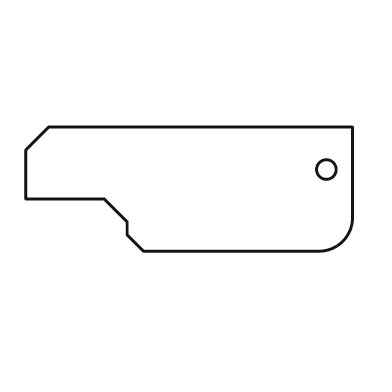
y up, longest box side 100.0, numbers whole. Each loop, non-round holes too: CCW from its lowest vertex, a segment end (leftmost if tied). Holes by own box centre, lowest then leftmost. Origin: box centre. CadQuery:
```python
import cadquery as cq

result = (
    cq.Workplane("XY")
    .moveTo(-14.0, -19.0)
    .lineTo(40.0, -19.0)
    .threePointArc((47.0, -16.0), (50.0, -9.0))
    .lineTo(50.0, 19.0)
    .lineTo(-43.0, 19.0)
    .lineTo(-50.0, 12.0)
    .lineTo(-50.0, -3.0)
    .lineTo(-26.0, -3.0)
    .lineTo(-19.0, -10.0)
    .lineTo(-19.0, -14.0)
    .close()
    .moveTo(42.0, 6.0)
    .circle(3.0)
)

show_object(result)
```